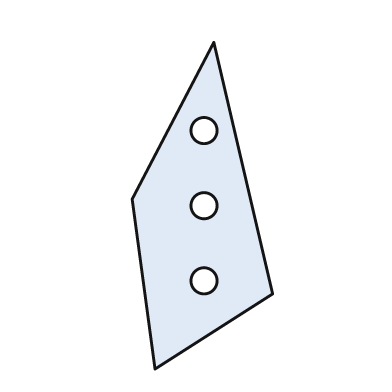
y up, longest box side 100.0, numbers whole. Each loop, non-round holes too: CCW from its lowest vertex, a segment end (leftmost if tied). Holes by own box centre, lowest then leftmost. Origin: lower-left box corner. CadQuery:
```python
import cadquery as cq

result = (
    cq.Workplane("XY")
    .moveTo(7.0, 0.0)
    .lineTo(43.0, 23.0)
    .lineTo(25.0, 100.0)
    .lineTo(0.0, 52.0)
    .close()
    .moveTo(22.0, 27.0)
    .circle(4.0)
    .moveTo(22.0, 50.0)
    .circle(4.0)
    .moveTo(22.0, 73.0)
    .circle(4.0)
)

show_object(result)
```